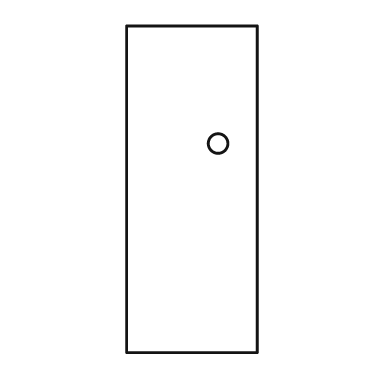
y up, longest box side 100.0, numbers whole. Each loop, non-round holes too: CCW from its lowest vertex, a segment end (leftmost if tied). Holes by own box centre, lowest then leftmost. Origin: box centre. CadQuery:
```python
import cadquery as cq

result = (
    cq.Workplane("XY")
    .moveTo(-20.0, -50.0)
    .lineTo(20.0, -50.0)
    .lineTo(20.0, 50.0)
    .lineTo(-20.0, 50.0)
    .close()
    .moveTo(8.0, 14.0)
    .circle(3.0)
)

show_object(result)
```